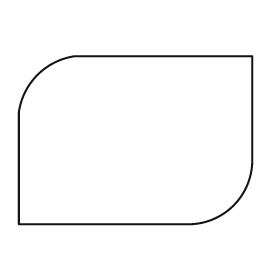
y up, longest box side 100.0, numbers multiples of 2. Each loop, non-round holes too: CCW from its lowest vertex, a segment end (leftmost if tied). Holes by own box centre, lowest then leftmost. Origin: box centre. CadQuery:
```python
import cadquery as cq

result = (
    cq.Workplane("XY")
    .moveTo(-50.0, -36.0)
    .lineTo(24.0, -36.0)
    .threePointArc((42.0, -28.0), (50.0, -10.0))
    .lineTo(50.0, 36.0)
    .lineTo(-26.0, 36.0)
    .threePointArc((-42.0, 28.0), (-50.0, 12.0))
    .close()
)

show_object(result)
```